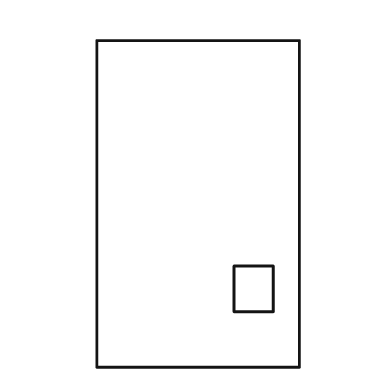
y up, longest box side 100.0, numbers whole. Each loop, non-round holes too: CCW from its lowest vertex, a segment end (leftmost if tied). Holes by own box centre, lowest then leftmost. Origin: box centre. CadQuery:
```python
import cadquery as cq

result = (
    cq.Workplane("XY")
    .moveTo(-31.0, -50.0)
    .lineTo(31.0, -50.0)
    .lineTo(31.0, 50.0)
    .lineTo(-31.0, 50.0)
    .close()
    .moveTo(11.0, -33.0)
    .lineTo(23.0, -33.0)
    .lineTo(23.0, -19.0)
    .lineTo(11.0, -19.0)
    .close()
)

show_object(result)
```